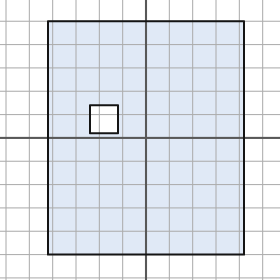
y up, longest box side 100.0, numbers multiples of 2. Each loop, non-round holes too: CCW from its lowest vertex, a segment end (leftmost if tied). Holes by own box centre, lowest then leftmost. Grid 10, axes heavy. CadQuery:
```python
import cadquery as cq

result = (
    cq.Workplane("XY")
    .moveTo(-42.0, -50.0)
    .lineTo(42.0, -50.0)
    .lineTo(42.0, 50.0)
    .lineTo(-42.0, 50.0)
    .close()
    .moveTo(-24.0, 2.0)
    .lineTo(-12.0, 2.0)
    .lineTo(-12.0, 14.0)
    .lineTo(-24.0, 14.0)
    .close()
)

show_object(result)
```